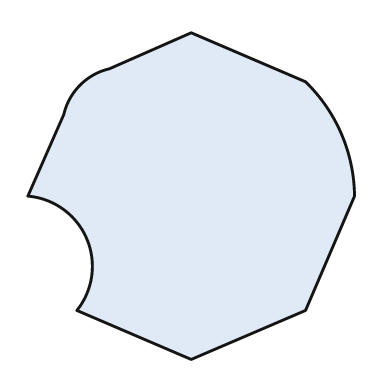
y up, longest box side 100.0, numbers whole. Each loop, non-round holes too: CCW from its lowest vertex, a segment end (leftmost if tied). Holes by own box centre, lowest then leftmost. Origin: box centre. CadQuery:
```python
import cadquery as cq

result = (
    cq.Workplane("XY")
    .moveTo(0.0, -50.0)
    .lineTo(35.0, -35.0)
    .lineTo(50.0, 0.0)
    .threePointArc((46.0, 19.0), (35.0, 35.0))
    .lineTo(0.0, 50.0)
    .lineTo(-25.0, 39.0)
    .threePointArc((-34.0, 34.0), (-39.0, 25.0))
    .lineTo(-50.0, 0.0)
    .threePointArc((-32.0, -13.0), (-35.0, -35.0))
    .close()
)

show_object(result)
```